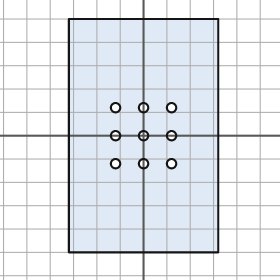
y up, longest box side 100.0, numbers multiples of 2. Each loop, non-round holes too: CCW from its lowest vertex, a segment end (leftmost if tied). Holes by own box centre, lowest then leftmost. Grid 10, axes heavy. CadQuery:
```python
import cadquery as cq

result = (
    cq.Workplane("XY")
    .moveTo(-32.0, -50.0)
    .lineTo(32.0, -50.0)
    .lineTo(32.0, 50.0)
    .lineTo(-32.0, 50.0)
    .close()
    .moveTo(-12.0, -12.0)
    .circle(2.0)
    .moveTo(0.0, -12.0)
    .circle(2.0)
    .moveTo(12.0, -12.0)
    .circle(2.0)
    .moveTo(-12.0, 0.0)
    .circle(2.0)
    .moveTo(0.0, 0.0)
    .circle(2.0)
    .moveTo(12.0, 0.0)
    .circle(2.0)
    .moveTo(-12.0, 12.0)
    .circle(2.0)
    .moveTo(0.0, 12.0)
    .circle(2.0)
    .moveTo(12.0, 12.0)
    .circle(2.0)
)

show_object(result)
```